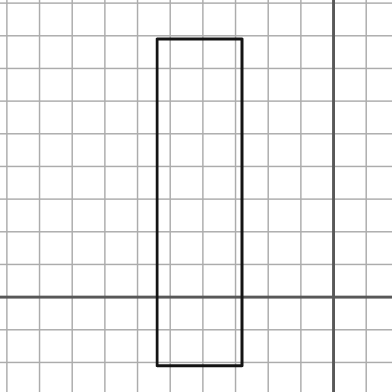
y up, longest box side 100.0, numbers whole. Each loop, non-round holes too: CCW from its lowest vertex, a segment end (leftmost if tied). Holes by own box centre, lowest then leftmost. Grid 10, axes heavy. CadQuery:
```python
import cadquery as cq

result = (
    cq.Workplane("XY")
    .moveTo(-54.0, -21.0)
    .lineTo(-28.0, -21.0)
    .lineTo(-28.0, 79.0)
    .lineTo(-54.0, 79.0)
    .close()
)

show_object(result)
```